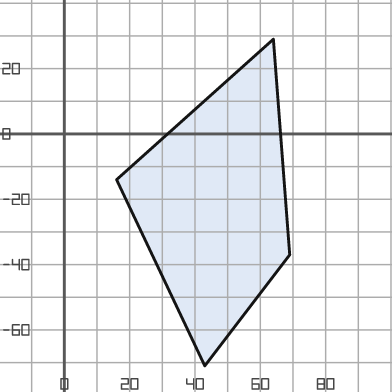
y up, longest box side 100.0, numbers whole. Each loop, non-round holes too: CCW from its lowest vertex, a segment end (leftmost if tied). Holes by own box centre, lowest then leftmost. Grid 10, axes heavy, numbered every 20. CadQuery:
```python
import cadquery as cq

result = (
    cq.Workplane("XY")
    .moveTo(43.0, -71.0)
    .lineTo(69.0, -37.0)
    .lineTo(64.0, 29.0)
    .lineTo(16.0, -14.0)
    .close()
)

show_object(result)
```